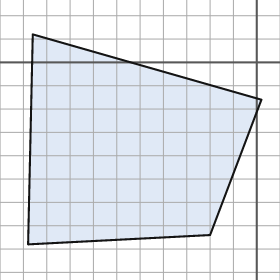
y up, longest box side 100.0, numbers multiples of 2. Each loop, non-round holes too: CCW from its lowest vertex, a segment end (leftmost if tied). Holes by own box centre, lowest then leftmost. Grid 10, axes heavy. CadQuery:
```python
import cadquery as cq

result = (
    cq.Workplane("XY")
    .moveTo(-98.0, -78.0)
    .lineTo(-20.0, -74.0)
    .lineTo(2.0, -16.0)
    .lineTo(-96.0, 12.0)
    .close()
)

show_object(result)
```